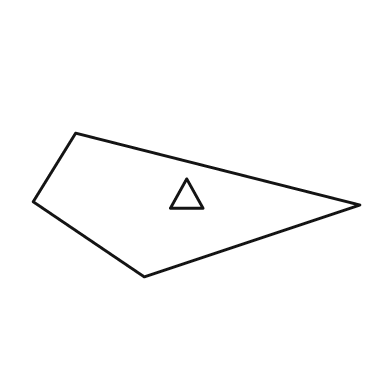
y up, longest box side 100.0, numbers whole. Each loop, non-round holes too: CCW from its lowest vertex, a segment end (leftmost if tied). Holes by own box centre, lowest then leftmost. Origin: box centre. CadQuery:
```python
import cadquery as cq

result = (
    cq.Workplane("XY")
    .moveTo(-16.0, -22.0)
    .lineTo(50.0, 0.0)
    .lineTo(-37.0, 22.0)
    .lineTo(-50.0, 1.0)
    .close()
    .moveTo(-8.0, -1.0)
    .lineTo(2.0, -1.0)
    .lineTo(-3.0, 8.0)
    .close()
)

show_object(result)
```